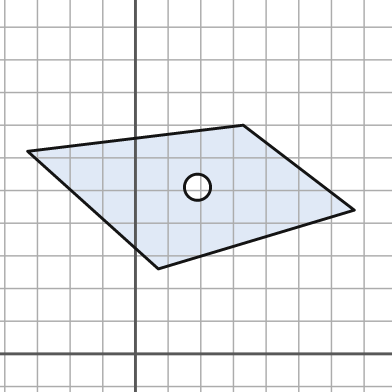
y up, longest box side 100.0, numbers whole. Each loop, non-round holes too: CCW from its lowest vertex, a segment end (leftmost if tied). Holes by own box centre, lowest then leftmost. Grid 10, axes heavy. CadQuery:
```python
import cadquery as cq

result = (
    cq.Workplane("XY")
    .moveTo(7.0, 26.0)
    .lineTo(67.0, 44.0)
    .lineTo(33.0, 70.0)
    .lineTo(-33.0, 62.0)
    .close()
    .moveTo(19.0, 51.0)
    .circle(4.0)
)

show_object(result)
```